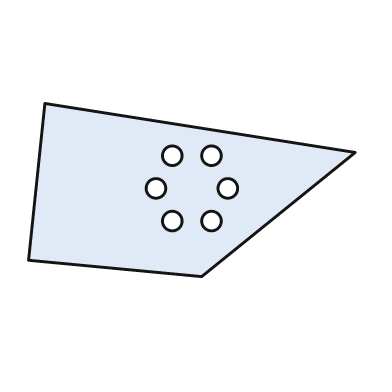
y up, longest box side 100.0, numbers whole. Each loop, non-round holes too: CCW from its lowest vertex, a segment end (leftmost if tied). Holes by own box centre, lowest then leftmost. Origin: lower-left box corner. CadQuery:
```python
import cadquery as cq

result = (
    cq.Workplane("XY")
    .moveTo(53.0, 0.0)
    .lineTo(100.0, 38.0)
    .lineTo(5.0, 53.0)
    .lineTo(0.0, 5.0)
    .close()
    .moveTo(44.0, 17.0)
    .circle(3.0)
    .moveTo(56.0, 17.0)
    .circle(3.0)
    .moveTo(39.0, 27.0)
    .circle(3.0)
    .moveTo(61.0, 27.0)
    .circle(3.0)
    .moveTo(44.0, 37.0)
    .circle(3.0)
    .moveTo(56.0, 37.0)
    .circle(3.0)
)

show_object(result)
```